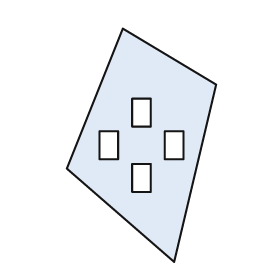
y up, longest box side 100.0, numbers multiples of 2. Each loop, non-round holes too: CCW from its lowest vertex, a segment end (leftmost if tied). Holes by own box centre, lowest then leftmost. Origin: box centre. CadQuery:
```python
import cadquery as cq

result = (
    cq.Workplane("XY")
    .moveTo(14.0, -50.0)
    .lineTo(32.0, 26.0)
    .lineTo(-8.0, 50.0)
    .lineTo(-32.0, -10.0)
    .close()
    .moveTo(-4.0, -20.0)
    .lineTo(4.0, -20.0)
    .lineTo(4.0, -8.0)
    .lineTo(-4.0, -8.0)
    .close()
    .moveTo(-18.0, -6.0)
    .lineTo(-10.0, -6.0)
    .lineTo(-10.0, 6.0)
    .lineTo(-18.0, 6.0)
    .close()
    .moveTo(10.0, -6.0)
    .lineTo(18.0, -6.0)
    .lineTo(18.0, 6.0)
    .lineTo(10.0, 6.0)
    .close()
    .moveTo(-4.0, 8.0)
    .lineTo(4.0, 8.0)
    .lineTo(4.0, 20.0)
    .lineTo(-4.0, 20.0)
    .close()
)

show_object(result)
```